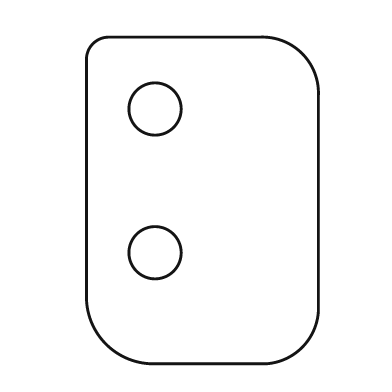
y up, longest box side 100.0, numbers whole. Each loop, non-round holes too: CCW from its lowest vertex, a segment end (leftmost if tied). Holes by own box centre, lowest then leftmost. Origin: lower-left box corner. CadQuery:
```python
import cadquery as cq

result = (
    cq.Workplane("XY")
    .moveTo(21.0, 0.0)
    .lineTo(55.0, 0.0)
    .threePointArc((66.0, 5.0), (71.0, 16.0))
    .lineTo(71.0, 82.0)
    .threePointArc((66.0, 95.0), (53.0, 100.0))
    .lineTo(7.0, 100.0)
    .threePointArc((2.0, 98.0), (0.0, 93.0))
    .lineTo(0.0, 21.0)
    .threePointArc((6.0, 6.0), (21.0, 0.0))
    .close()
    .moveTo(21.0, 34.0)
    .circle(8.0)
    .moveTo(21.0, 78.0)
    .circle(8.0)
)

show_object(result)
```